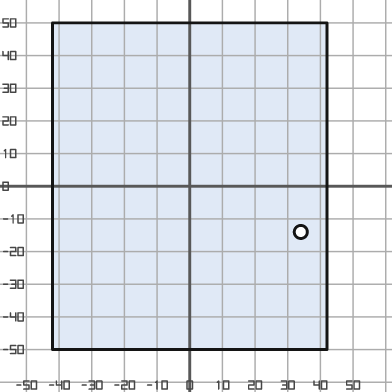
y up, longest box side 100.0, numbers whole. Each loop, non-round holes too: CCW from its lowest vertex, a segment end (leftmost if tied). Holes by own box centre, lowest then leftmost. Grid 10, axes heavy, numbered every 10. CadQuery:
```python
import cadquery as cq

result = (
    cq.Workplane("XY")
    .moveTo(-42.0, -50.0)
    .lineTo(42.0, -50.0)
    .lineTo(42.0, 50.0)
    .lineTo(-42.0, 50.0)
    .close()
    .moveTo(34.0, -14.0)
    .circle(2.0)
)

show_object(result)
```